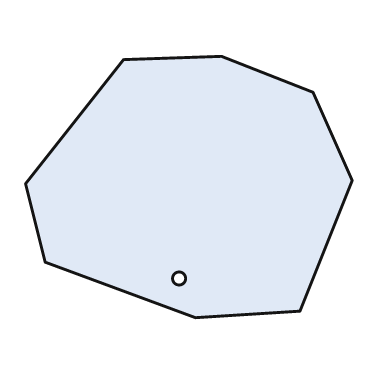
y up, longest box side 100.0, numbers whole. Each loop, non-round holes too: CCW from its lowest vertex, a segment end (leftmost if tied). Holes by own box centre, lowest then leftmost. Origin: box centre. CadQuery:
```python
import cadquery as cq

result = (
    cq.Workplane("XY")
    .moveTo(2.0, -40.0)
    .lineTo(34.0, -38.0)
    .lineTo(50.0, 2.0)
    .lineTo(38.0, 29.0)
    .lineTo(10.0, 40.0)
    .lineTo(-20.0, 39.0)
    .lineTo(-50.0, 1.0)
    .lineTo(-44.0, -23.0)
    .close()
    .moveTo(-3.0, -28.0)
    .circle(2.0)
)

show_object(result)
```